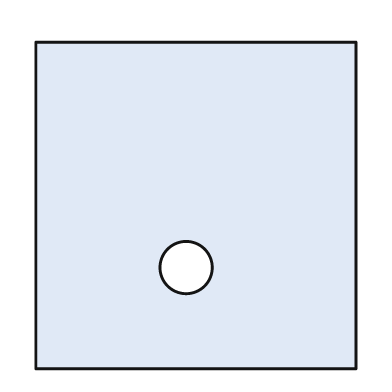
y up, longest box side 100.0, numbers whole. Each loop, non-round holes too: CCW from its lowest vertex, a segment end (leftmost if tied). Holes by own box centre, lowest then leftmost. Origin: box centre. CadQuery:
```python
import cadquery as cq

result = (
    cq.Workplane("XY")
    .moveTo(-49.0, -50.0)
    .lineTo(49.0, -50.0)
    .lineTo(49.0, 50.0)
    .lineTo(-49.0, 50.0)
    .close()
    .moveTo(-3.0, -19.0)
    .circle(8.0)
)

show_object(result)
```